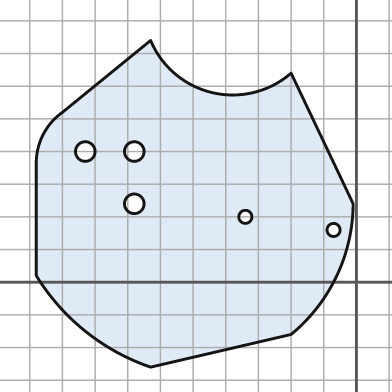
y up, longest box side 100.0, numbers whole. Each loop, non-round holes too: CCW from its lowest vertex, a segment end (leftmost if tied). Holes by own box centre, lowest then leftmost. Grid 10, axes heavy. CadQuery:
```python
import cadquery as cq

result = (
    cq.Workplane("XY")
    .moveTo(-63.0, -26.0)
    .lineTo(-20.0, -16.0)
    .threePointArc((-6.0, 2.0), (-1.0, 24.0))
    .lineTo(-20.0, 64.0)
    .threePointArc((-44.0, 58.0), (-63.0, 74.0))
    .lineTo(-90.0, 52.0)
    .threePointArc((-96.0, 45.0), (-98.0, 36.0))
    .lineTo(-98.0, 2.0)
    .threePointArc((-83.0, -15.0), (-63.0, -26.0))
    .close()
    .moveTo(-7.0, 16.0)
    .circle(2.0)
    .moveTo(-34.0, 20.0)
    .circle(2.0)
    .moveTo(-68.0, 24.0)
    .circle(3.0)
    .moveTo(-83.0, 40.0)
    .circle(3.0)
    .moveTo(-68.0, 40.0)
    .circle(3.0)
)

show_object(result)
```